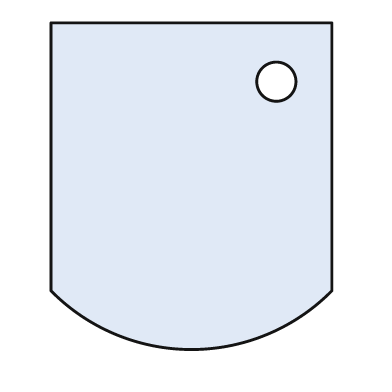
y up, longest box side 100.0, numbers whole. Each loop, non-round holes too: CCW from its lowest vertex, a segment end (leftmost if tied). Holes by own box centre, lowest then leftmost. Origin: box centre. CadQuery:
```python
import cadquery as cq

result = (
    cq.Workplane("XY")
    .moveTo(-43.0, -32.0)
    .threePointArc((0.0, -50.0), (43.0, -32.0))
    .lineTo(43.0, 50.0)
    .lineTo(-43.0, 50.0)
    .close()
    .moveTo(26.0, 32.0)
    .circle(6.0)
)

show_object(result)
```